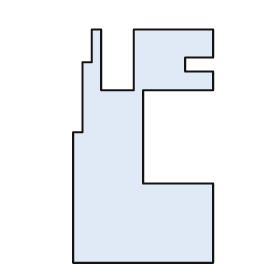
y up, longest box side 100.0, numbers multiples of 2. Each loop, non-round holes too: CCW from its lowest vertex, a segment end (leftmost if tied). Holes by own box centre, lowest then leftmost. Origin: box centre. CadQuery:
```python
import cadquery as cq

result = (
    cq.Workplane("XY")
    .moveTo(-30.0, -50.0)
    .lineTo(30.0, -50.0)
    .lineTo(30.0, -16.0)
    .lineTo(0.0, -16.0)
    .lineTo(0.0, 24.0)
    .lineTo(30.0, 24.0)
    .lineTo(30.0, 32.0)
    .lineTo(18.0, 32.0)
    .lineTo(18.0, 38.0)
    .lineTo(30.0, 38.0)
    .lineTo(30.0, 50.0)
    .lineTo(-4.0, 50.0)
    .lineTo(-4.0, 24.0)
    .lineTo(-18.0, 24.0)
    .lineTo(-18.0, 50.0)
    .lineTo(-22.0, 50.0)
    .lineTo(-22.0, 36.0)
    .lineTo(-26.0, 36.0)
    .lineTo(-26.0, 6.0)
    .lineTo(-30.0, 6.0)
    .close()
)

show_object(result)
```